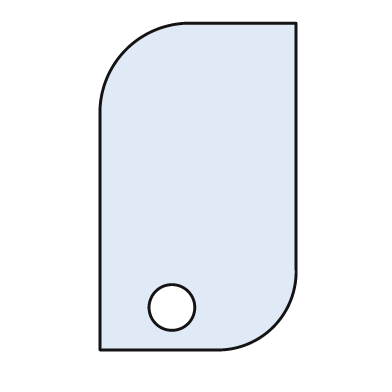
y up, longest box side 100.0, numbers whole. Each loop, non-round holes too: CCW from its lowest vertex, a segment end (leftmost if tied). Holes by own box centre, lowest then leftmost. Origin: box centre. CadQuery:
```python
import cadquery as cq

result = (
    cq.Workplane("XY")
    .moveTo(-30.0, -50.0)
    .lineTo(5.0, -50.0)
    .threePointArc((23.0, -43.0), (30.0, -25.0))
    .lineTo(30.0, 50.0)
    .lineTo(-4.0, 50.0)
    .threePointArc((-22.0, 42.0), (-30.0, 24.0))
    .close()
    .moveTo(-8.0, -37.0)
    .circle(7.0)
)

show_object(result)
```